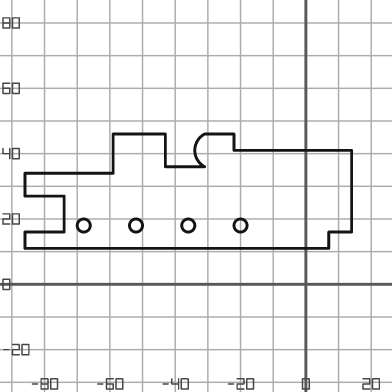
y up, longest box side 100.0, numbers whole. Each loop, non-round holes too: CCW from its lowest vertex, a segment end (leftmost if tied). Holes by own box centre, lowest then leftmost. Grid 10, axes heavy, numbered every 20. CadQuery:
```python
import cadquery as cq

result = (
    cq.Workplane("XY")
    .moveTo(-86.0, 11.0)
    .lineTo(7.0, 11.0)
    .lineTo(7.0, 16.0)
    .lineTo(14.0, 16.0)
    .lineTo(14.0, 41.0)
    .lineTo(-22.0, 41.0)
    .lineTo(-22.0, 46.0)
    .lineTo(-31.0, 46.0)
    .threePointArc((-34.0, 41.0), (-31.0, 36.0))
    .lineTo(-43.0, 36.0)
    .lineTo(-43.0, 46.0)
    .lineTo(-59.0, 46.0)
    .lineTo(-59.0, 34.0)
    .lineTo(-86.0, 34.0)
    .lineTo(-86.0, 27.0)
    .lineTo(-74.0, 27.0)
    .lineTo(-74.0, 16.0)
    .lineTo(-86.0, 16.0)
    .close()
    .moveTo(-68.0, 18.0)
    .circle(2.0)
    .moveTo(-52.0, 18.0)
    .circle(2.0)
    .moveTo(-36.0, 18.0)
    .circle(2.0)
    .moveTo(-20.0, 18.0)
    .circle(2.0)
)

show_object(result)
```